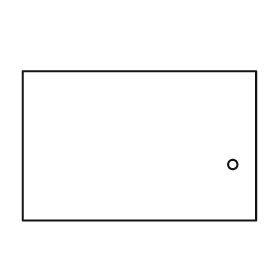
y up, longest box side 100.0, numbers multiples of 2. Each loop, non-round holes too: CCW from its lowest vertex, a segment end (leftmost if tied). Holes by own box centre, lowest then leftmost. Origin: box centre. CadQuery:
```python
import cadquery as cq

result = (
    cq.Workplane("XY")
    .moveTo(-50.0, -32.0)
    .lineTo(50.0, -32.0)
    .lineTo(50.0, 32.0)
    .lineTo(-50.0, 32.0)
    .close()
    .moveTo(40.0, -8.0)
    .circle(2.0)
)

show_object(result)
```